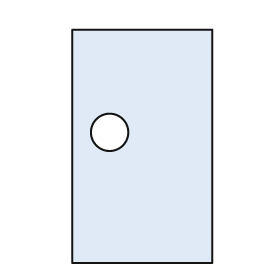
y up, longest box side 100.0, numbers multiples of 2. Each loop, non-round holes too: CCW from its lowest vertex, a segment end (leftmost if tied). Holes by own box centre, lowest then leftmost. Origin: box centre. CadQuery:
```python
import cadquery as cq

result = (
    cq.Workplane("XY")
    .moveTo(-30.0, -50.0)
    .lineTo(30.0, -50.0)
    .lineTo(30.0, 50.0)
    .lineTo(-30.0, 50.0)
    .close()
    .moveTo(-14.0, 6.0)
    .circle(8.0)
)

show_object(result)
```